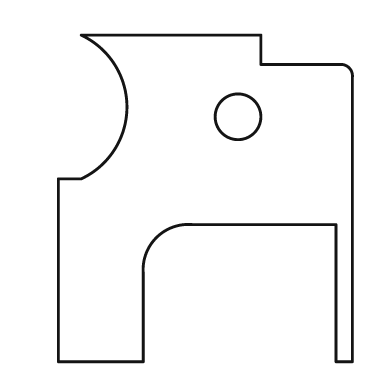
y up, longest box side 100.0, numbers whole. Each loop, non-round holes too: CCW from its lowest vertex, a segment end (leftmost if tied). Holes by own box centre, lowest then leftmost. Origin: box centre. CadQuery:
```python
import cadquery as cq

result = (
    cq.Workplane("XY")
    .moveTo(-45.0, -50.0)
    .lineTo(-19.0, -50.0)
    .lineTo(-19.0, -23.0)
    .threePointArc((-15.0, -12.0), (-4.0, -8.0))
    .lineTo(40.0, -8.0)
    .lineTo(40.0, -50.0)
    .lineTo(45.0, -50.0)
    .lineTo(45.0, 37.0)
    .threePointArc((44.0, 40.0), (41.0, 41.0))
    .lineTo(17.0, 41.0)
    .lineTo(17.0, 50.0)
    .lineTo(-38.0, 50.0)
    .threePointArc((-24.0, 28.0), (-38.0, 6.0))
    .lineTo(-45.0, 6.0)
    .close()
    .moveTo(10.0, 25.0)
    .circle(7.0)
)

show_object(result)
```